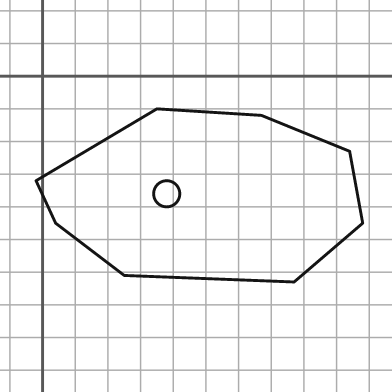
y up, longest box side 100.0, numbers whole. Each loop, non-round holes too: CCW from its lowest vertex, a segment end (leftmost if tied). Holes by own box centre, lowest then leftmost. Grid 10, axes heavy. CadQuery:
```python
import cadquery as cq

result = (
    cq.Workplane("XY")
    .moveTo(77.0, -63.0)
    .lineTo(98.0, -45.0)
    .lineTo(94.0, -23.0)
    .lineTo(67.0, -12.0)
    .lineTo(35.0, -10.0)
    .lineTo(-2.0, -32.0)
    .lineTo(4.0, -45.0)
    .lineTo(25.0, -61.0)
    .close()
    .moveTo(38.0, -36.0)
    .circle(4.0)
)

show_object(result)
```